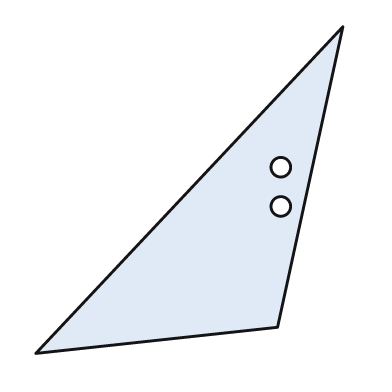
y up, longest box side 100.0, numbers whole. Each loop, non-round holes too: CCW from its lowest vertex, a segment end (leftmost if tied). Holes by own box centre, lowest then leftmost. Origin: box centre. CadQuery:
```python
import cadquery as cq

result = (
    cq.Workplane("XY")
    .moveTo(-47.0, -50.0)
    .lineTo(27.0, -42.0)
    .lineTo(47.0, 50.0)
    .close()
    .moveTo(28.0, -5.0)
    .circle(3.0)
    .moveTo(28.0, 7.0)
    .circle(3.0)
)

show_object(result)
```